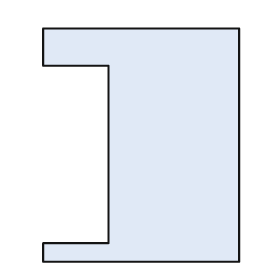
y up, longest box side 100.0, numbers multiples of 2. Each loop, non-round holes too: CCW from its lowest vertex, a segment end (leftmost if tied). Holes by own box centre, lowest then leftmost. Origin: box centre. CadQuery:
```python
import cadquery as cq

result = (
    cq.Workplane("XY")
    .moveTo(-42.0, -50.0)
    .lineTo(42.0, -50.0)
    .lineTo(42.0, 50.0)
    .lineTo(-42.0, 50.0)
    .lineTo(-42.0, 34.0)
    .lineTo(-14.0, 34.0)
    .lineTo(-14.0, -42.0)
    .lineTo(-42.0, -42.0)
    .close()
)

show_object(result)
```